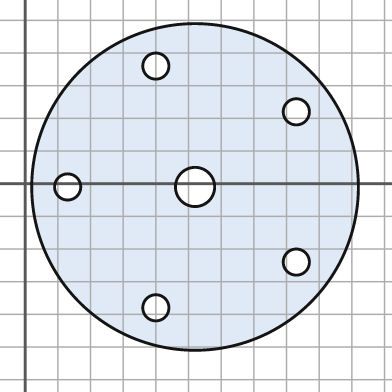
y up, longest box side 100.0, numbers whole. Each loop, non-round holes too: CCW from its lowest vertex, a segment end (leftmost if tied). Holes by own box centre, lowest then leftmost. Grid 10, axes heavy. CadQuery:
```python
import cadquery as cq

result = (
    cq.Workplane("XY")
    .moveTo(52.0, -1.0)
    .circle(50.0)
    .moveTo(40.0, -38.0)
    .circle(4.0)
    .moveTo(83.0, -24.0)
    .circle(4.0)
    .moveTo(13.0, -1.0)
    .circle(4.0)
    .moveTo(52.0, -1.0)
    .circle(6.0)
    .moveTo(83.0, 22.0)
    .circle(4.0)
    .moveTo(40.0, 36.0)
    .circle(4.0)
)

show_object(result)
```